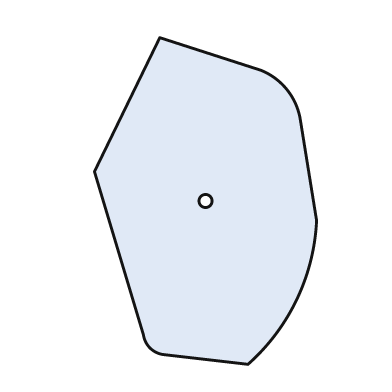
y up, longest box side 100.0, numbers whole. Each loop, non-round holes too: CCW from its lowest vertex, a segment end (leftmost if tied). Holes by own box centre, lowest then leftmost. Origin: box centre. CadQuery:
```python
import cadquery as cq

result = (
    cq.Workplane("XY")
    .moveTo(13.0, -50.0)
    .threePointArc((28.0, -30.0), (34.0, -6.0))
    .lineTo(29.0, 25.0)
    .threePointArc((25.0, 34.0), (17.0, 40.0))
    .lineTo(-14.0, 50.0)
    .lineTo(-34.0, 9.0)
    .lineTo(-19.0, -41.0)
    .threePointArc((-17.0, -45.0), (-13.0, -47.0))
    .close()
    .moveTo(0.0, 0.0)
    .circle(2.0)
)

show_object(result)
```